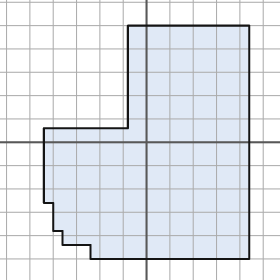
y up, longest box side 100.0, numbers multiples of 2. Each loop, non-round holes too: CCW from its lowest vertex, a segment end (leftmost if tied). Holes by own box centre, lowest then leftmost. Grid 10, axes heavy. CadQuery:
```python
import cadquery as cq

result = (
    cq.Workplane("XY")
    .moveTo(-24.0, -50.0)
    .lineTo(44.0, -50.0)
    .lineTo(44.0, 50.0)
    .lineTo(-8.0, 50.0)
    .lineTo(-8.0, 6.0)
    .lineTo(-44.0, 6.0)
    .lineTo(-44.0, -26.0)
    .lineTo(-40.0, -26.0)
    .lineTo(-40.0, -38.0)
    .lineTo(-36.0, -38.0)
    .lineTo(-36.0, -44.0)
    .lineTo(-24.0, -44.0)
    .close()
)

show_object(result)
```